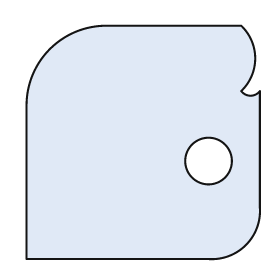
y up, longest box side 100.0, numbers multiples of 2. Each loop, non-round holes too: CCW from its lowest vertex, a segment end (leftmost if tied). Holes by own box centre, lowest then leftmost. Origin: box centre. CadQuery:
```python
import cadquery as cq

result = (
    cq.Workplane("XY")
    .moveTo(-50.0, -50.0)
    .lineTo(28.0, -50.0)
    .threePointArc((44.0, -44.0), (50.0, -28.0))
    .lineTo(50.0, 22.0)
    .threePointArc((46.0, 20.0), (42.0, 22.0))
    .threePointArc((48.0, 36.0), (42.0, 50.0))
    .lineTo(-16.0, 50.0)
    .threePointArc((-40.0, 40.0), (-50.0, 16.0))
    .close()
    .moveTo(28.0, -8.0)
    .circle(10.0)
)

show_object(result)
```